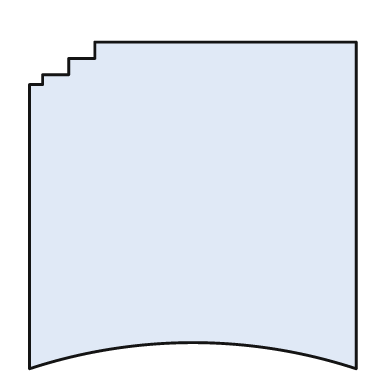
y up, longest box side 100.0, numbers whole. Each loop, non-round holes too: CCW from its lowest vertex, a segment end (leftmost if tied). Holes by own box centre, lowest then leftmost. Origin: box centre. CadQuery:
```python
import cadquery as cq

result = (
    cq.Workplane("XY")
    .moveTo(-50.0, -50.0)
    .threePointArc((0.0, -42.0), (50.0, -50.0))
    .lineTo(50.0, 50.0)
    .lineTo(-30.0, 50.0)
    .lineTo(-30.0, 45.0)
    .lineTo(-38.0, 45.0)
    .lineTo(-38.0, 40.0)
    .lineTo(-46.0, 40.0)
    .lineTo(-46.0, 37.0)
    .lineTo(-50.0, 37.0)
    .close()
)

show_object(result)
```